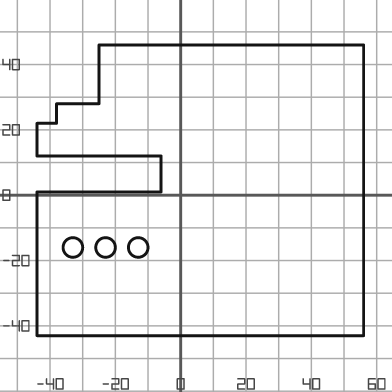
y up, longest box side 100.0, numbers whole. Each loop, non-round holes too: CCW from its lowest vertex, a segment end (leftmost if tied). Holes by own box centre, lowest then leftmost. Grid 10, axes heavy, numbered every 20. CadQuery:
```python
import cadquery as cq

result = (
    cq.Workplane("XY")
    .moveTo(-44.0, -43.0)
    .lineTo(56.0, -43.0)
    .lineTo(56.0, 46.0)
    .lineTo(-25.0, 46.0)
    .lineTo(-25.0, 28.0)
    .lineTo(-38.0, 28.0)
    .lineTo(-38.0, 22.0)
    .lineTo(-44.0, 22.0)
    .lineTo(-44.0, 12.0)
    .lineTo(-6.0, 12.0)
    .lineTo(-6.0, 1.0)
    .lineTo(-44.0, 1.0)
    .close()
    .moveTo(-33.0, -16.0)
    .circle(3.0)
    .moveTo(-23.0, -16.0)
    .circle(3.0)
    .moveTo(-13.0, -16.0)
    .circle(3.0)
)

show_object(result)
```